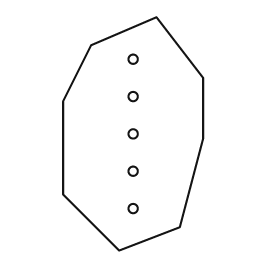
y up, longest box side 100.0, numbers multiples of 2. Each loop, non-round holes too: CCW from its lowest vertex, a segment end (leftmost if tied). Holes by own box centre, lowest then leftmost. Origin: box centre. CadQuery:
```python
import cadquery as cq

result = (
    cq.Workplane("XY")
    .moveTo(-6.0, -50.0)
    .lineTo(20.0, -40.0)
    .lineTo(30.0, -2.0)
    .lineTo(30.0, 24.0)
    .lineTo(10.0, 50.0)
    .lineTo(-18.0, 38.0)
    .lineTo(-30.0, 14.0)
    .lineTo(-30.0, -26.0)
    .close()
    .moveTo(0.0, -32.0)
    .circle(2.0)
    .moveTo(0.0, -16.0)
    .circle(2.0)
    .moveTo(0.0, 0.0)
    .circle(2.0)
    .moveTo(0.0, 16.0)
    .circle(2.0)
    .moveTo(0.0, 32.0)
    .circle(2.0)
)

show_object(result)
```